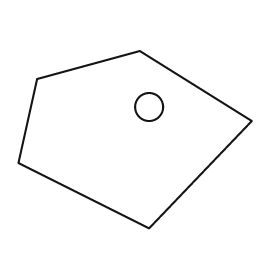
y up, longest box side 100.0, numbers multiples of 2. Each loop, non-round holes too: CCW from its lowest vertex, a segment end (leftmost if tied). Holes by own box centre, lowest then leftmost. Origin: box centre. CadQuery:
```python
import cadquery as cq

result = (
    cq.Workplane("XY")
    .moveTo(6.0, -38.0)
    .lineTo(50.0, 8.0)
    .lineTo(2.0, 38.0)
    .lineTo(-42.0, 26.0)
    .lineTo(-50.0, -10.0)
    .close()
    .moveTo(6.0, 14.0)
    .circle(6.0)
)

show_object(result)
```